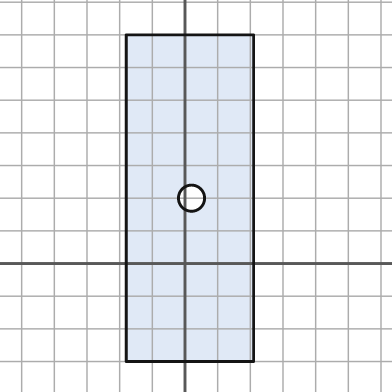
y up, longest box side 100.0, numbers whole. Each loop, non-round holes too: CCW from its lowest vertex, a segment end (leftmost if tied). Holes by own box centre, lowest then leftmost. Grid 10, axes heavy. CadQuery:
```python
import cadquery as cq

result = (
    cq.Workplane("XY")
    .moveTo(-18.0, -30.0)
    .lineTo(21.0, -30.0)
    .lineTo(21.0, 70.0)
    .lineTo(-18.0, 70.0)
    .close()
    .moveTo(2.0, 20.0)
    .circle(4.0)
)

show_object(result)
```